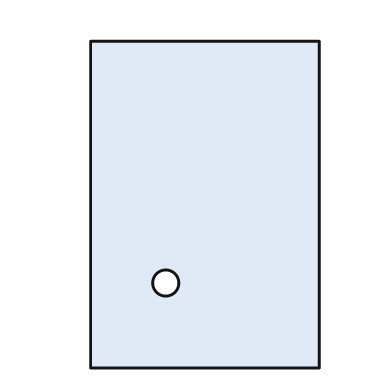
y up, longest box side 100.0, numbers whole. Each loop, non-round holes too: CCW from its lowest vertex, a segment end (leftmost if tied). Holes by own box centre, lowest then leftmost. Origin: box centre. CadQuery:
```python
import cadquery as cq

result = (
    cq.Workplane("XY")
    .moveTo(-35.0, -50.0)
    .lineTo(35.0, -50.0)
    .lineTo(35.0, 50.0)
    .lineTo(-35.0, 50.0)
    .close()
    .moveTo(-12.0, -24.0)
    .circle(4.0)
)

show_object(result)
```